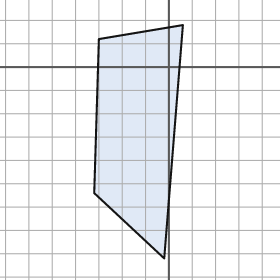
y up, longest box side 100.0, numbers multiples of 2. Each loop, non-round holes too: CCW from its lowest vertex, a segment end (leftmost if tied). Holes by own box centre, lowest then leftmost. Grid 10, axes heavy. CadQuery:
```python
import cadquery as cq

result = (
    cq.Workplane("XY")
    .moveTo(-2.0, -82.0)
    .lineTo(6.0, 18.0)
    .lineTo(-30.0, 12.0)
    .lineTo(-32.0, -54.0)
    .close()
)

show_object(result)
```